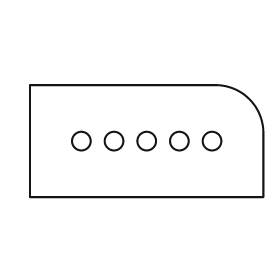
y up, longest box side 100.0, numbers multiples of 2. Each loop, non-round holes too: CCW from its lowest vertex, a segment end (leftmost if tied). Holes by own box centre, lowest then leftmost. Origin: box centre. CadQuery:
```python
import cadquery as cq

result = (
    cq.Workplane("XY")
    .moveTo(-50.0, -24.0)
    .lineTo(50.0, -24.0)
    .lineTo(50.0, 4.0)
    .threePointArc((44.0, 18.0), (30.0, 24.0))
    .lineTo(-50.0, 24.0)
    .close()
    .moveTo(-28.0, 0.0)
    .circle(4.0)
    .moveTo(-14.0, 0.0)
    .circle(4.0)
    .moveTo(0.0, 0.0)
    .circle(4.0)
    .moveTo(14.0, 0.0)
    .circle(4.0)
    .moveTo(28.0, 0.0)
    .circle(4.0)
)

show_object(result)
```